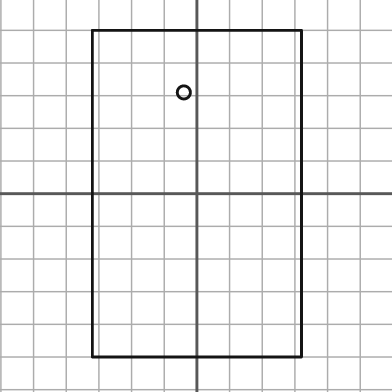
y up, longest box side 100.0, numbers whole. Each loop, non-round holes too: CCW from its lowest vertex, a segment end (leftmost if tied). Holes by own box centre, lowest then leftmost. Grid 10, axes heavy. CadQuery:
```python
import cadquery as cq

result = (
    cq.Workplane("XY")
    .moveTo(-32.0, -50.0)
    .lineTo(32.0, -50.0)
    .lineTo(32.0, 50.0)
    .lineTo(-32.0, 50.0)
    .close()
    .moveTo(-4.0, 31.0)
    .circle(2.0)
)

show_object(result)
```